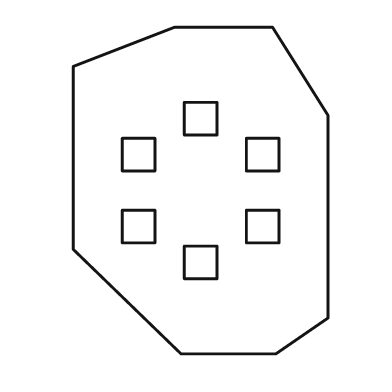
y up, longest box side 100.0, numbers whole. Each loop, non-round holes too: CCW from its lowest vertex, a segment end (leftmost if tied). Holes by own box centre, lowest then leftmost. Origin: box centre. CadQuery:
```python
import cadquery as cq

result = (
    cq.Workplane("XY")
    .moveTo(-6.0, -50.0)
    .lineTo(23.0, -50.0)
    .lineTo(39.0, -39.0)
    .lineTo(39.0, 23.0)
    .lineTo(22.0, 50.0)
    .lineTo(-8.0, 50.0)
    .lineTo(-39.0, 38.0)
    .lineTo(-39.0, -18.0)
    .close()
    .moveTo(-5.0, -27.0)
    .lineTo(5.0, -27.0)
    .lineTo(5.0, -17.0)
    .lineTo(-5.0, -17.0)
    .close()
    .moveTo(-24.0, -16.0)
    .lineTo(-14.0, -16.0)
    .lineTo(-14.0, -6.0)
    .lineTo(-24.0, -6.0)
    .close()
    .moveTo(14.0, -16.0)
    .lineTo(24.0, -16.0)
    .lineTo(24.0, -6.0)
    .lineTo(14.0, -6.0)
    .close()
    .moveTo(-24.0, 6.0)
    .lineTo(-14.0, 6.0)
    .lineTo(-14.0, 16.0)
    .lineTo(-24.0, 16.0)
    .close()
    .moveTo(14.0, 6.0)
    .lineTo(24.0, 6.0)
    .lineTo(24.0, 16.0)
    .lineTo(14.0, 16.0)
    .close()
    .moveTo(-5.0, 17.0)
    .lineTo(5.0, 17.0)
    .lineTo(5.0, 27.0)
    .lineTo(-5.0, 27.0)
    .close()
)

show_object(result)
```